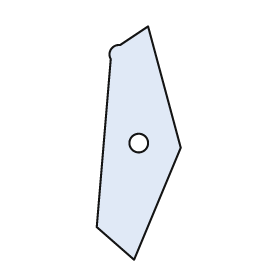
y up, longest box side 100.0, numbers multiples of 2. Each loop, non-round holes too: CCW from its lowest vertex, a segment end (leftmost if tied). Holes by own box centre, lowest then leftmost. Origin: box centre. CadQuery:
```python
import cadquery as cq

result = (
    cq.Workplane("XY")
    .moveTo(-2.0, -50.0)
    .lineTo(18.0, -2.0)
    .lineTo(4.0, 50.0)
    .lineTo(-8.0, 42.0)
    .threePointArc((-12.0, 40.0), (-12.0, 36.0))
    .lineTo(-18.0, -36.0)
    .close()
    .moveTo(0.0, 0.0)
    .circle(4.0)
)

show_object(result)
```